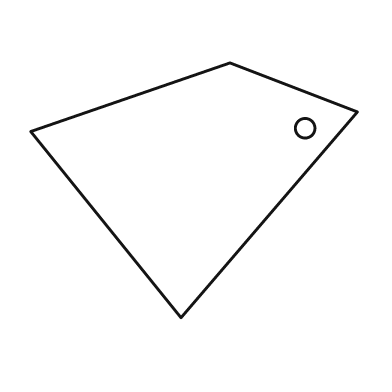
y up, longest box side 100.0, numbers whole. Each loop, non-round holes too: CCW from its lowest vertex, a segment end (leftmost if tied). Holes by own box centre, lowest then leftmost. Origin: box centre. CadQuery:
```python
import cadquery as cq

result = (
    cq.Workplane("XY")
    .moveTo(-4.0, -39.0)
    .lineTo(50.0, 24.0)
    .lineTo(11.0, 39.0)
    .lineTo(-50.0, 18.0)
    .close()
    .moveTo(34.0, 19.0)
    .circle(3.0)
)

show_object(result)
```